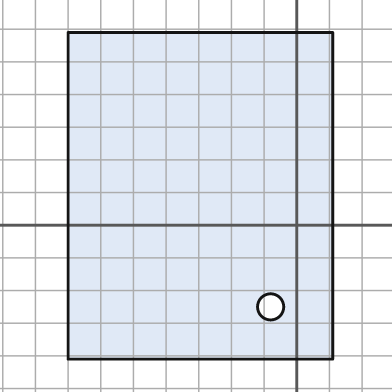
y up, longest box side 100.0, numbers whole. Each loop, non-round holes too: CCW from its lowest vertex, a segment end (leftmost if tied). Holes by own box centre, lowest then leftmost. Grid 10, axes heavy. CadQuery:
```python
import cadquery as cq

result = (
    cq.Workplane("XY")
    .moveTo(-70.0, -41.0)
    .lineTo(11.0, -41.0)
    .lineTo(11.0, 59.0)
    .lineTo(-70.0, 59.0)
    .close()
    .moveTo(-8.0, -25.0)
    .circle(4.0)
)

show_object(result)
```